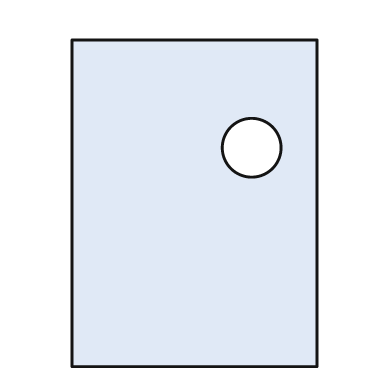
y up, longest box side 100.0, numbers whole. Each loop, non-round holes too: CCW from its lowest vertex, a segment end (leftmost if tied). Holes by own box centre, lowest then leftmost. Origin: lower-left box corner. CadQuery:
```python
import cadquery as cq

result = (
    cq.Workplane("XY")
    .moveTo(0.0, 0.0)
    .lineTo(75.0, 0.0)
    .lineTo(75.0, 100.0)
    .lineTo(0.0, 100.0)
    .close()
    .moveTo(55.0, 67.0)
    .circle(9.0)
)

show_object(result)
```